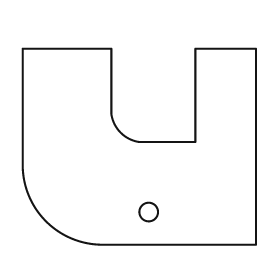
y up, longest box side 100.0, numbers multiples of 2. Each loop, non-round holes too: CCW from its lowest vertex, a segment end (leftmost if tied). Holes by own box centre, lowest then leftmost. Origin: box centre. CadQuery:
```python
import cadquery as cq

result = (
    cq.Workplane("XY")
    .moveTo(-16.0, -42.0)
    .lineTo(50.0, -42.0)
    .lineTo(50.0, 42.0)
    .lineTo(24.0, 42.0)
    .lineTo(24.0, 2.0)
    .lineTo(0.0, 2.0)
    .threePointArc((-8.0, 6.0), (-12.0, 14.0))
    .lineTo(-12.0, 42.0)
    .lineTo(-50.0, 42.0)
    .lineTo(-50.0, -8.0)
    .threePointArc((-40.0, -32.0), (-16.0, -42.0))
    .close()
    .moveTo(4.0, -28.0)
    .circle(4.0)
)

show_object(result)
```